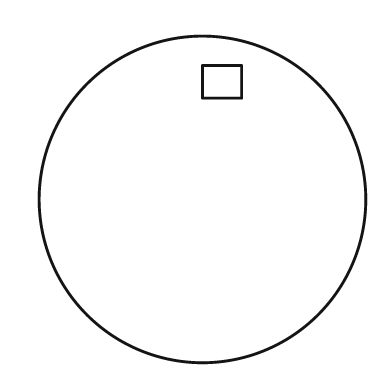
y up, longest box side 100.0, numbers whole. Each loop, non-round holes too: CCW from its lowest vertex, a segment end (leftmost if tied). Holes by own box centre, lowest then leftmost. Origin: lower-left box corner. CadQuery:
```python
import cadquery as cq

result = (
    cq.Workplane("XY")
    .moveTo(50.0, 50.0)
    .circle(50.0)
    .moveTo(50.0, 81.0)
    .lineTo(62.0, 81.0)
    .lineTo(62.0, 91.0)
    .lineTo(50.0, 91.0)
    .close()
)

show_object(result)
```